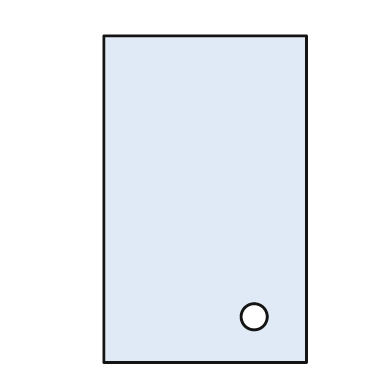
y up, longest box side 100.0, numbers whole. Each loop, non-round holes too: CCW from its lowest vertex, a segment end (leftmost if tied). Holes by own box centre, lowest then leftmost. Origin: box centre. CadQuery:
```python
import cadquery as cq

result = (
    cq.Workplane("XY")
    .moveTo(-31.0, -50.0)
    .lineTo(31.0, -50.0)
    .lineTo(31.0, 50.0)
    .lineTo(-31.0, 50.0)
    .close()
    .moveTo(15.0, -36.0)
    .circle(4.0)
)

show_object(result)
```